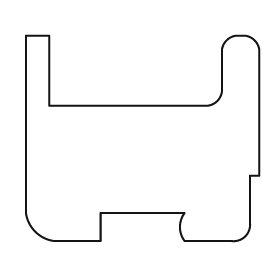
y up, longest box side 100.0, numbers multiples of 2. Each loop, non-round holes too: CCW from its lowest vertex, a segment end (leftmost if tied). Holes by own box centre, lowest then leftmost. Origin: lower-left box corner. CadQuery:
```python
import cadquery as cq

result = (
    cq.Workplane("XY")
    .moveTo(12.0, 0.0)
    .lineTo(32.0, 0.0)
    .lineTo(32.0, 12.0)
    .lineTo(68.0, 12.0)
    .threePointArc((66.0, 6.0), (68.0, 0.0))
    .lineTo(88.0, 0.0)
    .threePointArc((94.0, 2.0), (96.0, 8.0))
    .lineTo(96.0, 28.0)
    .lineTo(100.0, 28.0)
    .lineTo(100.0, 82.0)
    .threePointArc((98.0, 86.0), (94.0, 88.0))
    .lineTo(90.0, 88.0)
    .threePointArc((86.0, 86.0), (84.0, 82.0))
    .lineTo(84.0, 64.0)
    .threePointArc((82.0, 60.0), (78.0, 58.0))
    .lineTo(10.0, 58.0)
    .lineTo(10.0, 88.0)
    .lineTo(0.0, 88.0)
    .lineTo(0.0, 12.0)
    .threePointArc((4.0, 4.0), (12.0, 0.0))
    .close()
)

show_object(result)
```